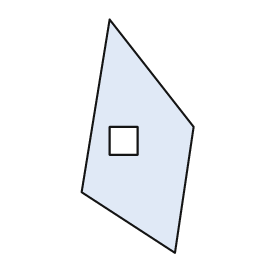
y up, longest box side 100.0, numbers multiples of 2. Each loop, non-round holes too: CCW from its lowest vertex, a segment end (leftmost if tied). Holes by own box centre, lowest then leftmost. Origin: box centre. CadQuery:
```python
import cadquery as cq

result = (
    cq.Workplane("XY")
    .moveTo(16.0, -50.0)
    .lineTo(24.0, 4.0)
    .lineTo(-12.0, 50.0)
    .lineTo(-24.0, -24.0)
    .close()
    .moveTo(-12.0, -8.0)
    .lineTo(0.0, -8.0)
    .lineTo(0.0, 4.0)
    .lineTo(-12.0, 4.0)
    .close()
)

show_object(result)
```